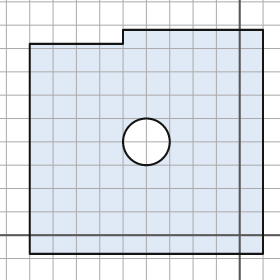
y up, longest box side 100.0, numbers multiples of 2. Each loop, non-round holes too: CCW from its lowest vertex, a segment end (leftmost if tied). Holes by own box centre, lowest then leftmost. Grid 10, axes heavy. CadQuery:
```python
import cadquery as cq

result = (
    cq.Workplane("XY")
    .moveTo(-90.0, -8.0)
    .lineTo(10.0, -8.0)
    .lineTo(10.0, 88.0)
    .lineTo(-50.0, 88.0)
    .lineTo(-50.0, 82.0)
    .lineTo(-90.0, 82.0)
    .close()
    .moveTo(-40.0, 40.0)
    .circle(10.0)
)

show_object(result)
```